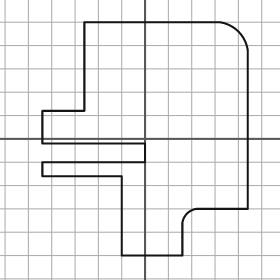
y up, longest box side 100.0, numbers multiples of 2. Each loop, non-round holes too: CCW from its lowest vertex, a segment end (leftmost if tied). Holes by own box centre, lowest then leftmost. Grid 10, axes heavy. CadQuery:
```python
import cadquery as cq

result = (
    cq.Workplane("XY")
    .moveTo(-10.0, -50.0)
    .lineTo(16.0, -50.0)
    .lineTo(16.0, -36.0)
    .threePointArc((18.0, -32.0), (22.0, -30.0))
    .lineTo(44.0, -30.0)
    .lineTo(44.0, 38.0)
    .threePointArc((40.0, 46.0), (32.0, 50.0))
    .lineTo(-26.0, 50.0)
    .lineTo(-26.0, 12.0)
    .lineTo(-44.0, 12.0)
    .lineTo(-44.0, -2.0)
    .lineTo(0.0, -2.0)
    .lineTo(0.0, -10.0)
    .lineTo(-44.0, -10.0)
    .lineTo(-44.0, -16.0)
    .lineTo(-10.0, -16.0)
    .close()
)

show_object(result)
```